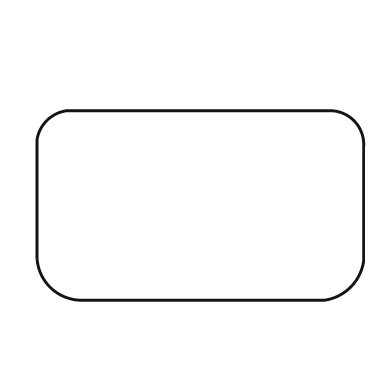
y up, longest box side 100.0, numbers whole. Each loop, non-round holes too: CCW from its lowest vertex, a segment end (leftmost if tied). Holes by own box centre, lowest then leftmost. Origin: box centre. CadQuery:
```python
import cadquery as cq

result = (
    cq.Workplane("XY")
    .moveTo(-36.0, -29.0)
    .lineTo(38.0, -29.0)
    .threePointArc((46.0, -25.0), (50.0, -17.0))
    .lineTo(50.0, 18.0)
    .threePointArc((47.0, 26.0), (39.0, 29.0))
    .lineTo(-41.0, 29.0)
    .threePointArc((-47.0, 26.0), (-50.0, 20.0))
    .lineTo(-50.0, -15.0)
    .threePointArc((-46.0, -25.0), (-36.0, -29.0))
    .close()
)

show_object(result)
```